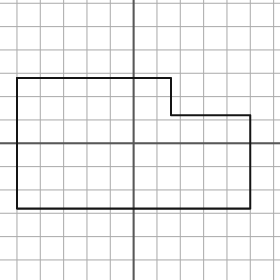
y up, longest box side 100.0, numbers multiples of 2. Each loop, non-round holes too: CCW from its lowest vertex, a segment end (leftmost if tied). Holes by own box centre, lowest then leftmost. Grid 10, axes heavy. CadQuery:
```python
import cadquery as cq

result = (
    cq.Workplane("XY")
    .moveTo(-50.0, -28.0)
    .lineTo(50.0, -28.0)
    .lineTo(50.0, 12.0)
    .lineTo(16.0, 12.0)
    .lineTo(16.0, 28.0)
    .lineTo(-50.0, 28.0)
    .close()
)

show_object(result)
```